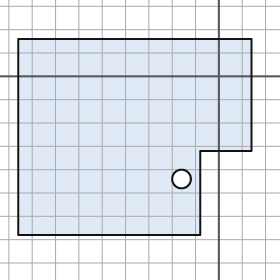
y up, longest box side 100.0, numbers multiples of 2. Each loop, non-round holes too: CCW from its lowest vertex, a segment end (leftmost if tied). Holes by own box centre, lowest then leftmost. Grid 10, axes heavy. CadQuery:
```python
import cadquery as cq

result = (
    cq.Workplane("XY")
    .moveTo(-86.0, -68.0)
    .lineTo(-8.0, -68.0)
    .lineTo(-8.0, -32.0)
    .lineTo(14.0, -32.0)
    .lineTo(14.0, 16.0)
    .lineTo(-86.0, 16.0)
    .close()
    .moveTo(-16.0, -44.0)
    .circle(4.0)
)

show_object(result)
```